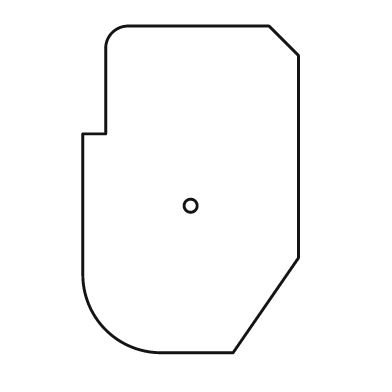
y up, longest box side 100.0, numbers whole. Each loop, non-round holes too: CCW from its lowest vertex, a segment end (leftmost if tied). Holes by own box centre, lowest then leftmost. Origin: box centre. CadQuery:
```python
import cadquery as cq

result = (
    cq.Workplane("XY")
    .moveTo(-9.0, -50.0)
    .lineTo(13.0, -50.0)
    .lineTo(33.0, -21.0)
    .lineTo(33.0, 41.0)
    .lineTo(24.0, 50.0)
    .lineTo(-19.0, 50.0)
    .threePointArc((-24.0, 48.0), (-26.0, 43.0))
    .lineTo(-26.0, 17.0)
    .lineTo(-33.0, 17.0)
    .lineTo(-33.0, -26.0)
    .threePointArc((-26.0, -43.0), (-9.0, -50.0))
    .close()
    .moveTo(0.0, -5.0)
    .circle(2.0)
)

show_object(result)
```